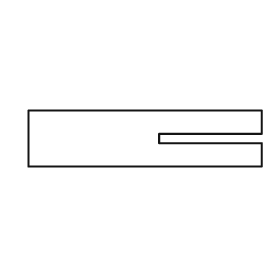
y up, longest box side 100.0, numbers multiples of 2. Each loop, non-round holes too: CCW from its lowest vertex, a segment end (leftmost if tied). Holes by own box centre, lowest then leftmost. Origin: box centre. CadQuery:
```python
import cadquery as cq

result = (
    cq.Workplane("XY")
    .moveTo(-50.0, -12.0)
    .lineTo(50.0, -12.0)
    .lineTo(50.0, -2.0)
    .lineTo(6.0, -2.0)
    .lineTo(6.0, 2.0)
    .lineTo(50.0, 2.0)
    .lineTo(50.0, 12.0)
    .lineTo(-50.0, 12.0)
    .close()
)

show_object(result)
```